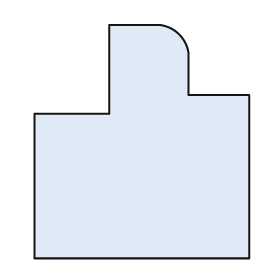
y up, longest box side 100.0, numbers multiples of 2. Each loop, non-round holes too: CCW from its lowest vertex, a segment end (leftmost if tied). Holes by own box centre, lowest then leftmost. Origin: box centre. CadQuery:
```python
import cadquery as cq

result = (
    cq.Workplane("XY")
    .moveTo(-46.0, -50.0)
    .lineTo(46.0, -50.0)
    .lineTo(46.0, 20.0)
    .lineTo(20.0, 20.0)
    .lineTo(20.0, 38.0)
    .threePointArc((16.0, 46.0), (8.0, 50.0))
    .lineTo(-14.0, 50.0)
    .lineTo(-14.0, 12.0)
    .lineTo(-46.0, 12.0)
    .close()
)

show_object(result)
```